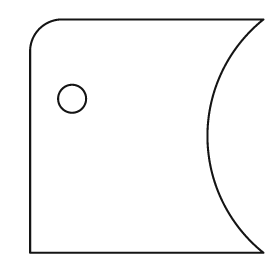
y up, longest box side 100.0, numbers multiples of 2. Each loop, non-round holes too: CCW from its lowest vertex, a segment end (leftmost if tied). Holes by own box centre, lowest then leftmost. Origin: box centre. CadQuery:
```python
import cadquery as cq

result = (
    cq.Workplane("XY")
    .moveTo(-50.0, -50.0)
    .lineTo(50.0, -50.0)
    .threePointArc((26.0, 0.0), (50.0, 50.0))
    .lineTo(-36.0, 50.0)
    .threePointArc((-46.0, 46.0), (-50.0, 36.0))
    .close()
    .moveTo(-32.0, 16.0)
    .circle(6.0)
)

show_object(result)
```